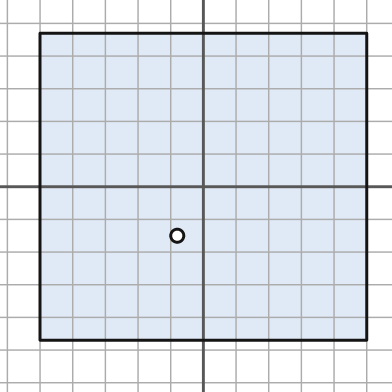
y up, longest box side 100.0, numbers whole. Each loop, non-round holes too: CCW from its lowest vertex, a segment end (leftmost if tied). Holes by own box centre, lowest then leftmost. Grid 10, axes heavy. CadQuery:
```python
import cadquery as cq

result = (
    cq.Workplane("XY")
    .moveTo(-50.0, -47.0)
    .lineTo(50.0, -47.0)
    .lineTo(50.0, 47.0)
    .lineTo(-50.0, 47.0)
    .close()
    .moveTo(-8.0, -15.0)
    .circle(2.0)
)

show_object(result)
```